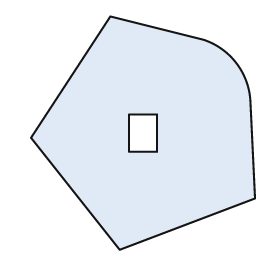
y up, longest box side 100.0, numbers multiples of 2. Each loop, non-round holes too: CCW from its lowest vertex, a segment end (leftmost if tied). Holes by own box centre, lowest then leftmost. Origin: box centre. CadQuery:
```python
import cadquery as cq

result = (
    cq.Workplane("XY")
    .moveTo(-10.0, -50.0)
    .lineTo(48.0, -28.0)
    .lineTo(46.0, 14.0)
    .threePointArc((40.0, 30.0), (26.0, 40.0))
    .lineTo(-14.0, 50.0)
    .lineTo(-48.0, -2.0)
    .close()
    .moveTo(-6.0, -8.0)
    .lineTo(6.0, -8.0)
    .lineTo(6.0, 8.0)
    .lineTo(-6.0, 8.0)
    .close()
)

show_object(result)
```